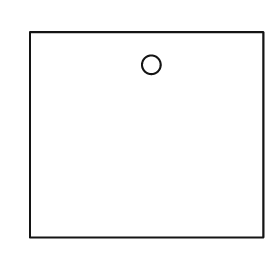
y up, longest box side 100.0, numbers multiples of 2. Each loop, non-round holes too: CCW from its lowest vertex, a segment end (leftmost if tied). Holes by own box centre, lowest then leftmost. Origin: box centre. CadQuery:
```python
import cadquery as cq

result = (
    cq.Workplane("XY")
    .moveTo(-50.0, -44.0)
    .lineTo(50.0, -44.0)
    .lineTo(50.0, 44.0)
    .lineTo(-50.0, 44.0)
    .close()
    .moveTo(2.0, 30.0)
    .circle(4.0)
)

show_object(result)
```